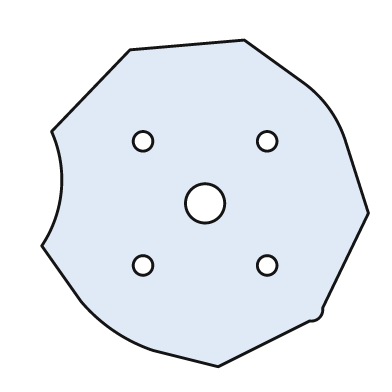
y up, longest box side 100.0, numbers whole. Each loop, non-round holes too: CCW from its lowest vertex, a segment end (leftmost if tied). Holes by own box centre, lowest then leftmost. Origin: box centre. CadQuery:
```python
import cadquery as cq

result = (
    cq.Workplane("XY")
    .moveTo(4.0, -50.0)
    .lineTo(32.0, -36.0)
    .threePointArc((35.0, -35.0), (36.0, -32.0))
    .lineTo(50.0, -3.0)
    .lineTo(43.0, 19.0)
    .threePointArc((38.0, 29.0), (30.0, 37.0))
    .lineTo(12.0, 50.0)
    .lineTo(-23.0, 47.0)
    .lineTo(-47.0, 22.0)
    .threePointArc((-44.0, 4.0), (-50.0, -13.0))
    .lineTo(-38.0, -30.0)
    .threePointArc((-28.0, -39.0), (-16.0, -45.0))
    .close()
    .moveTo(-19.0, -19.0)
    .circle(3.0)
    .moveTo(19.0, -19.0)
    .circle(3.0)
    .moveTo(0.0, 0.0)
    .circle(6.0)
    .moveTo(-19.0, 19.0)
    .circle(3.0)
    .moveTo(19.0, 19.0)
    .circle(3.0)
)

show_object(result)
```